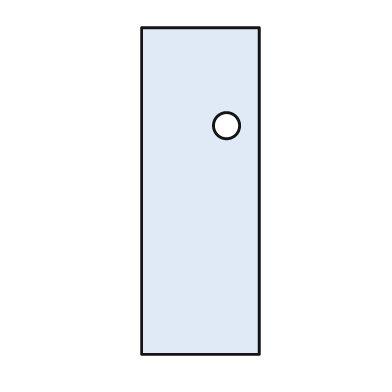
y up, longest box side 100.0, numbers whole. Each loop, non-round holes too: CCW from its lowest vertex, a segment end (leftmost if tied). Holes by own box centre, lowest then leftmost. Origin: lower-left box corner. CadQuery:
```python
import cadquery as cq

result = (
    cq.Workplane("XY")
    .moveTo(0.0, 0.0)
    .lineTo(36.0, 0.0)
    .lineTo(36.0, 100.0)
    .lineTo(0.0, 100.0)
    .close()
    .moveTo(26.0, 70.0)
    .circle(4.0)
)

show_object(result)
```